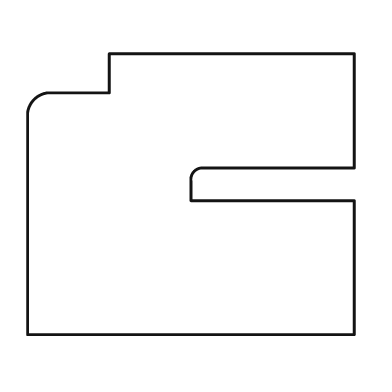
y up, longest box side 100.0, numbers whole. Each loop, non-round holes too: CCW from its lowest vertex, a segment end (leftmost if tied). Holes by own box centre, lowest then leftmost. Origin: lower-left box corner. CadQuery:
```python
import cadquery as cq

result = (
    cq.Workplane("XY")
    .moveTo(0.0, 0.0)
    .lineTo(100.0, 0.0)
    .lineTo(100.0, 41.0)
    .lineTo(50.0, 41.0)
    .lineTo(50.0, 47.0)
    .threePointArc((51.0, 50.0), (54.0, 51.0))
    .lineTo(100.0, 51.0)
    .lineTo(100.0, 86.0)
    .lineTo(25.0, 86.0)
    .lineTo(25.0, 74.0)
    .lineTo(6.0, 74.0)
    .threePointArc((2.0, 72.0), (0.0, 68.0))
    .close()
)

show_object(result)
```